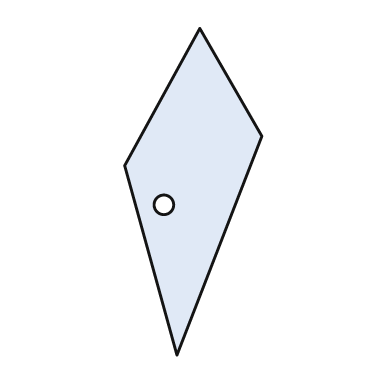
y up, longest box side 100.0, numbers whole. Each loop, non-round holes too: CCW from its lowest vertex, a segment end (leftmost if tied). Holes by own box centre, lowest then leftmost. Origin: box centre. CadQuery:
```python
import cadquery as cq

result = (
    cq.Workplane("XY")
    .moveTo(-5.0, -50.0)
    .lineTo(21.0, 17.0)
    .lineTo(2.0, 50.0)
    .lineTo(-21.0, 8.0)
    .close()
    .moveTo(-9.0, -4.0)
    .circle(3.0)
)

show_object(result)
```